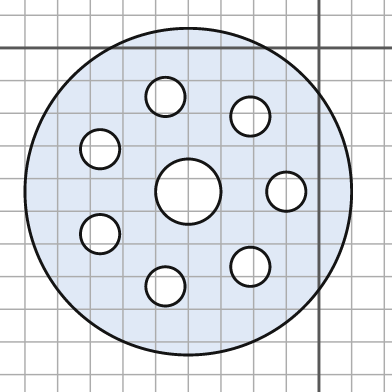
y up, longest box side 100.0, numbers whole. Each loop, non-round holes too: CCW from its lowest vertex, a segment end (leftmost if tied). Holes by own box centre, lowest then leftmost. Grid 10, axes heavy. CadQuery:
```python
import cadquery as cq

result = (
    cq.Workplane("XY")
    .moveTo(-40.0, -44.0)
    .circle(50.0)
    .moveTo(-47.0, -73.0)
    .circle(6.0)
    .moveTo(-21.0, -67.0)
    .circle(6.0)
    .moveTo(-67.0, -57.0)
    .circle(6.0)
    .moveTo(-40.0, -44.0)
    .circle(10.0)
    .moveTo(-10.0, -44.0)
    .circle(6.0)
    .moveTo(-67.0, -31.0)
    .circle(6.0)
    .moveTo(-21.0, -21.0)
    .circle(6.0)
    .moveTo(-47.0, -15.0)
    .circle(6.0)
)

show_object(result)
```